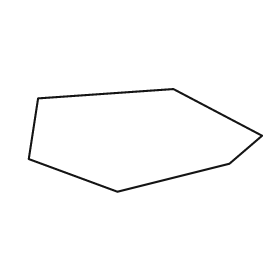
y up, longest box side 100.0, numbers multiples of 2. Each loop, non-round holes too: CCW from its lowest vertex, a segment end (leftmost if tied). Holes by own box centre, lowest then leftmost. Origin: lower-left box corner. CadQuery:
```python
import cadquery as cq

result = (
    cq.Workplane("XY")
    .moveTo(38.0, 0.0)
    .lineTo(86.0, 12.0)
    .lineTo(100.0, 24.0)
    .lineTo(62.0, 44.0)
    .lineTo(4.0, 40.0)
    .lineTo(0.0, 14.0)
    .close()
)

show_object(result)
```